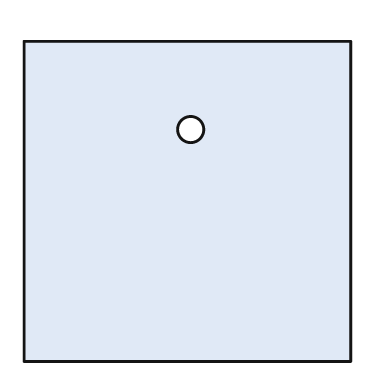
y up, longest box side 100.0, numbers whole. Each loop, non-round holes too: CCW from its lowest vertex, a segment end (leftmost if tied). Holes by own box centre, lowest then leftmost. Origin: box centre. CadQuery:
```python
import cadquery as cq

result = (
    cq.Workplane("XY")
    .moveTo(-50.0, -49.0)
    .lineTo(50.0, -49.0)
    .lineTo(50.0, 49.0)
    .lineTo(-50.0, 49.0)
    .close()
    .moveTo(1.0, 22.0)
    .circle(4.0)
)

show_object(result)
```